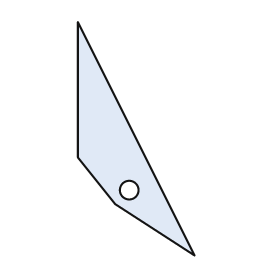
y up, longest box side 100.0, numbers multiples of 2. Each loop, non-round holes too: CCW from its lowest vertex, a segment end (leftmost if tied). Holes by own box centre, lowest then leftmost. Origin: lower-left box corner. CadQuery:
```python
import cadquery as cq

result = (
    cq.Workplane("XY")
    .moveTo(50.0, 0.0)
    .lineTo(0.0, 100.0)
    .lineTo(0.0, 42.0)
    .lineTo(16.0, 22.0)
    .close()
    .moveTo(22.0, 28.0)
    .circle(4.0)
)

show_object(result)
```